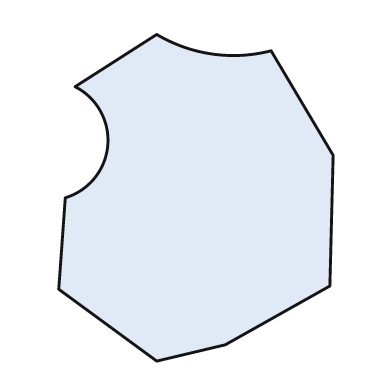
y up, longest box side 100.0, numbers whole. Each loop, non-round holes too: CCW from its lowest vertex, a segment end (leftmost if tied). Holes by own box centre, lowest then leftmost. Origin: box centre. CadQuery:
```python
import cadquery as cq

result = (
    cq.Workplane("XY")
    .moveTo(-12.0, -50.0)
    .lineTo(9.0, -45.0)
    .lineTo(41.0, -27.0)
    .lineTo(42.0, 13.0)
    .lineTo(23.0, 45.0)
    .threePointArc((5.0, 44.0), (-12.0, 50.0))
    .lineTo(-37.0, 34.0)
    .threePointArc((-27.0, 16.0), (-40.0, 0.0))
    .lineTo(-42.0, -28.0)
    .close()
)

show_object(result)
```